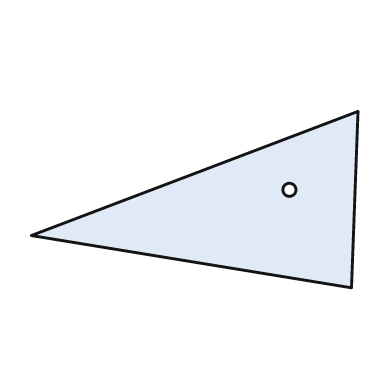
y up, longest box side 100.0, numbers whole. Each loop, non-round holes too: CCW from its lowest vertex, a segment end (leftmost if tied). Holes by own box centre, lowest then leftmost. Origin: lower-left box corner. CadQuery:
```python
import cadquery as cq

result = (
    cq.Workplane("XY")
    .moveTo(98.0, 0.0)
    .lineTo(100.0, 54.0)
    .lineTo(0.0, 16.0)
    .close()
    .moveTo(79.0, 30.0)
    .circle(2.0)
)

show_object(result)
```